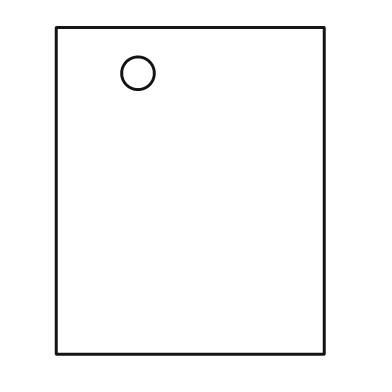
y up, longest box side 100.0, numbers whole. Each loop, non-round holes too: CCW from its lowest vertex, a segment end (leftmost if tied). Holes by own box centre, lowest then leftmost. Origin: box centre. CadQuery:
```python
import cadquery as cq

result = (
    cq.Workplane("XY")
    .moveTo(-41.0, -50.0)
    .lineTo(41.0, -50.0)
    .lineTo(41.0, 50.0)
    .lineTo(-41.0, 50.0)
    .close()
    .moveTo(-16.0, 36.0)
    .circle(5.0)
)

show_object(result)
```